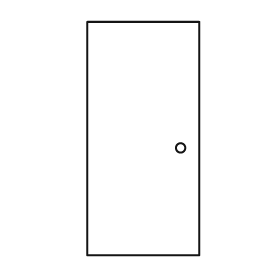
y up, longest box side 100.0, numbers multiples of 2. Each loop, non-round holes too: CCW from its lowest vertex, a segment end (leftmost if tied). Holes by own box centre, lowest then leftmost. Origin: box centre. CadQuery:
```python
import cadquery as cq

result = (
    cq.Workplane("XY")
    .moveTo(-24.0, -50.0)
    .lineTo(24.0, -50.0)
    .lineTo(24.0, 50.0)
    .lineTo(-24.0, 50.0)
    .close()
    .moveTo(16.0, -4.0)
    .circle(2.0)
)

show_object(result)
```